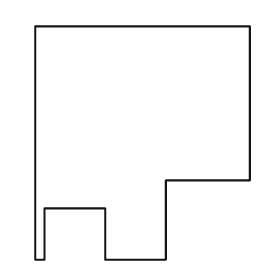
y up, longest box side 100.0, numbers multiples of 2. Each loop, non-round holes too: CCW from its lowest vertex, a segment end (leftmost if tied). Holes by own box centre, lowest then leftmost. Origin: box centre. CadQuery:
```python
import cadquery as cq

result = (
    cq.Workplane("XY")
    .moveTo(-46.0, -50.0)
    .lineTo(-42.0, -50.0)
    .lineTo(-42.0, -28.0)
    .lineTo(-16.0, -28.0)
    .lineTo(-16.0, -50.0)
    .lineTo(10.0, -50.0)
    .lineTo(10.0, -16.0)
    .lineTo(46.0, -16.0)
    .lineTo(46.0, 50.0)
    .lineTo(-46.0, 50.0)
    .close()
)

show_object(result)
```